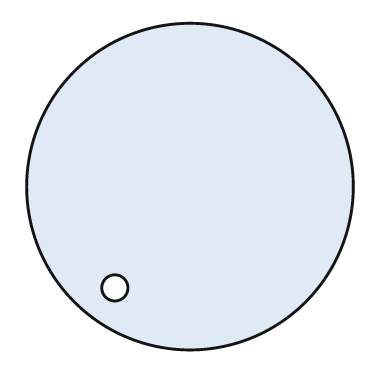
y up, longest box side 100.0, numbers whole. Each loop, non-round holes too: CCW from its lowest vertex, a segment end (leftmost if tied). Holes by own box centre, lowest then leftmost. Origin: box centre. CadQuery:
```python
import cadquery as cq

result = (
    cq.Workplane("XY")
    .moveTo(0.0, 0.0)
    .circle(50.0)
    .moveTo(-23.0, -31.0)
    .circle(4.0)
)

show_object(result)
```